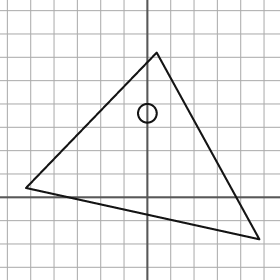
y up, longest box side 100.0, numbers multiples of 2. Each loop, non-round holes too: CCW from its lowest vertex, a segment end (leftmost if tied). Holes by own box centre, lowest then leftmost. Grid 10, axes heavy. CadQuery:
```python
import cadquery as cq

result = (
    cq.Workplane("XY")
    .moveTo(48.0, -18.0)
    .lineTo(4.0, 62.0)
    .lineTo(-52.0, 4.0)
    .close()
    .moveTo(0.0, 36.0)
    .circle(4.0)
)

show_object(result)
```